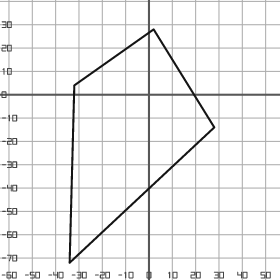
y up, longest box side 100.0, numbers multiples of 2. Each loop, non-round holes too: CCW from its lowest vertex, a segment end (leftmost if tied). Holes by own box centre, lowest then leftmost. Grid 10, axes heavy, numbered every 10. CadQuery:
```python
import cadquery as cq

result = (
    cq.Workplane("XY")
    .moveTo(-34.0, -72.0)
    .lineTo(28.0, -14.0)
    .lineTo(2.0, 28.0)
    .lineTo(-32.0, 4.0)
    .close()
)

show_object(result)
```